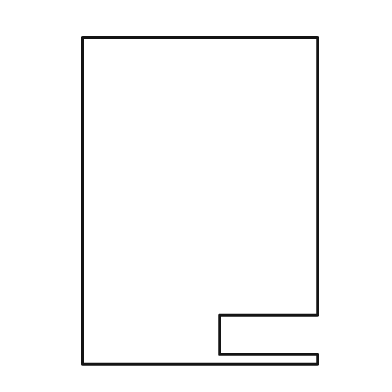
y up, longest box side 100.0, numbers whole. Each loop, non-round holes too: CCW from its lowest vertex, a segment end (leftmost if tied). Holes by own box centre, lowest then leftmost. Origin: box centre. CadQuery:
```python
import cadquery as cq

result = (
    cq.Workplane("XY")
    .moveTo(-36.0, -50.0)
    .lineTo(36.0, -50.0)
    .lineTo(36.0, -47.0)
    .lineTo(6.0, -47.0)
    .lineTo(6.0, -35.0)
    .lineTo(36.0, -35.0)
    .lineTo(36.0, 50.0)
    .lineTo(-36.0, 50.0)
    .close()
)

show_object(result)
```